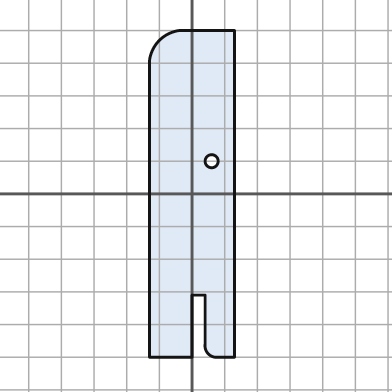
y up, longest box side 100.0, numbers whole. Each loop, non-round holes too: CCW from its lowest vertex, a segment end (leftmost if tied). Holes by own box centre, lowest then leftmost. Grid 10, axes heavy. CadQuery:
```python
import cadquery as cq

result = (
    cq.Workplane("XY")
    .moveTo(-13.0, -50.0)
    .lineTo(0.0, -50.0)
    .lineTo(0.0, -31.0)
    .lineTo(4.0, -31.0)
    .lineTo(4.0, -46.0)
    .threePointArc((5.0, -49.0), (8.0, -50.0))
    .lineTo(13.0, -50.0)
    .lineTo(13.0, 50.0)
    .lineTo(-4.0, 50.0)
    .threePointArc((-10.0, 47.0), (-13.0, 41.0))
    .close()
    .moveTo(6.0, 10.0)
    .circle(2.0)
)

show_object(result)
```